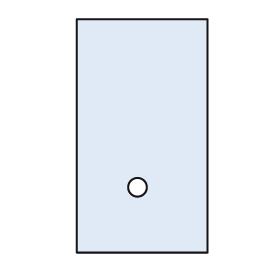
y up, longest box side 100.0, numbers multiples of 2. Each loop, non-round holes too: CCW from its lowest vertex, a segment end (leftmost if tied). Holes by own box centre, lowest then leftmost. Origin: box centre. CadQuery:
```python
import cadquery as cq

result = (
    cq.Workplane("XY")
    .moveTo(-28.0, -50.0)
    .lineTo(28.0, -50.0)
    .lineTo(28.0, 50.0)
    .lineTo(-28.0, 50.0)
    .close()
    .moveTo(-2.0, -22.0)
    .circle(4.0)
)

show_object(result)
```